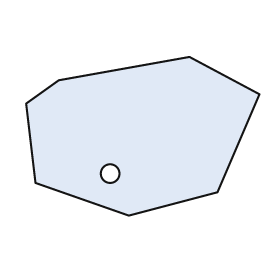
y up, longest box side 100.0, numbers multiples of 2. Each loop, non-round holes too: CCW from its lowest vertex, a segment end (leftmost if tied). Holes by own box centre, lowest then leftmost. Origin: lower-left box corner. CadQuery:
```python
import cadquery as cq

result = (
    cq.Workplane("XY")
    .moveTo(44.0, 0.0)
    .lineTo(82.0, 10.0)
    .lineTo(100.0, 52.0)
    .lineTo(70.0, 68.0)
    .lineTo(14.0, 58.0)
    .lineTo(0.0, 48.0)
    .lineTo(4.0, 14.0)
    .close()
    .moveTo(36.0, 18.0)
    .circle(4.0)
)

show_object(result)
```